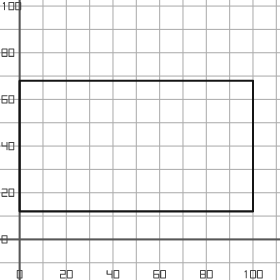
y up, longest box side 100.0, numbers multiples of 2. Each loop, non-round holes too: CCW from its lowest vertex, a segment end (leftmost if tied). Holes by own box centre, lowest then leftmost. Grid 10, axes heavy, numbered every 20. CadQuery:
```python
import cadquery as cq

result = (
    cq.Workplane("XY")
    .moveTo(0.0, 12.0)
    .lineTo(100.0, 12.0)
    .lineTo(100.0, 68.0)
    .lineTo(0.0, 68.0)
    .close()
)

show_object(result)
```